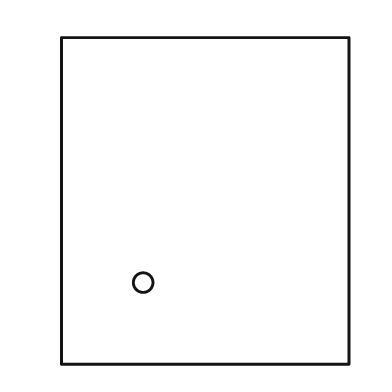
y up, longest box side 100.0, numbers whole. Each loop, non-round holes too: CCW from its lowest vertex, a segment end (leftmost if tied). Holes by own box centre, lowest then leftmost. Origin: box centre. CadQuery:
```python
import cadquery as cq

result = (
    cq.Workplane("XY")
    .moveTo(-44.0, -50.0)
    .lineTo(44.0, -50.0)
    .lineTo(44.0, 50.0)
    .lineTo(-44.0, 50.0)
    .close()
    .moveTo(-19.0, -25.0)
    .circle(3.0)
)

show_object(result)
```